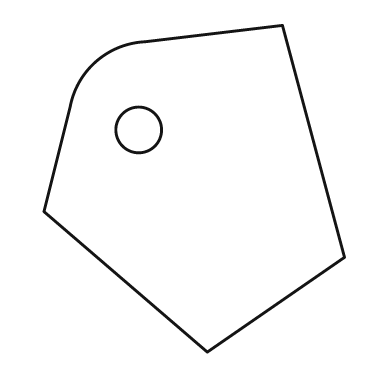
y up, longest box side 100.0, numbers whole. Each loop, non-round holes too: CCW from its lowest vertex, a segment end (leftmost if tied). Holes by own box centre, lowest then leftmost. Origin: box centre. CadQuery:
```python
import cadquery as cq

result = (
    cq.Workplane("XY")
    .moveTo(4.0, -50.0)
    .lineTo(46.0, -21.0)
    .lineTo(27.0, 50.0)
    .lineTo(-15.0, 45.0)
    .threePointArc((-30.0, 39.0), (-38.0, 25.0))
    .lineTo(-46.0, -7.0)
    .close()
    .moveTo(-17.0, 18.0)
    .circle(7.0)
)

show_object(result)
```